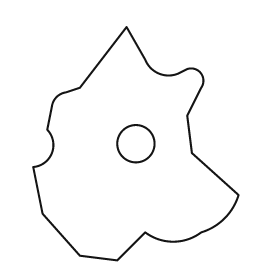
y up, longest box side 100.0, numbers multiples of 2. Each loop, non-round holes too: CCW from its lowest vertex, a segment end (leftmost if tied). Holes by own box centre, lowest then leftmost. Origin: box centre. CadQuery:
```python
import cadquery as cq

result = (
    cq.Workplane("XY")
    .moveTo(-8.0, -50.0)
    .lineTo(4.0, -38.0)
    .threePointArc((16.0, -42.0), (28.0, -38.0))
    .threePointArc((38.0, -32.0), (44.0, -22.0))
    .lineTo(24.0, -4.0)
    .lineTo(22.0, 12.0)
    .lineTo(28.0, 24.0)
    .threePointArc((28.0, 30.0), (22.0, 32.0))
    .lineTo(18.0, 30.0)
    .threePointArc((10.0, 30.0), (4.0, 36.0))
    .lineTo(-4.0, 50.0)
    .lineTo(-24.0, 24.0)
    .lineTo(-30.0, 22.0)
    .threePointArc((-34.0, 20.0), (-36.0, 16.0))
    .lineTo(-38.0, 6.0)
    .threePointArc((-36.0, -4.0), (-44.0, -10.0))
    .lineTo(-40.0, -30.0)
    .lineTo(-24.0, -48.0)
    .close()
    .moveTo(0.0, 0.0)
    .circle(8.0)
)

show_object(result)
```